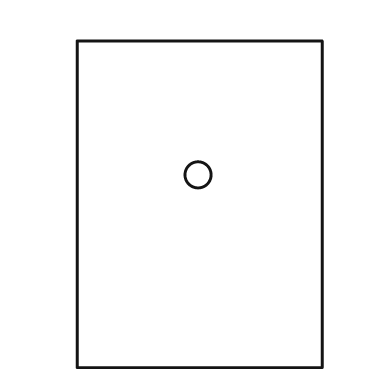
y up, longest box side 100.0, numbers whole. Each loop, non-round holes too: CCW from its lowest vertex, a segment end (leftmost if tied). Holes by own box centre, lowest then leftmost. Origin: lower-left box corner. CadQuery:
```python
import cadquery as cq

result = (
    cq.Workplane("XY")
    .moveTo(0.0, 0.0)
    .lineTo(75.0, 0.0)
    .lineTo(75.0, 100.0)
    .lineTo(0.0, 100.0)
    .close()
    .moveTo(37.0, 59.0)
    .circle(4.0)
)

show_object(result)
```